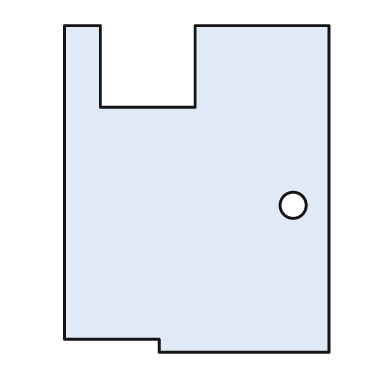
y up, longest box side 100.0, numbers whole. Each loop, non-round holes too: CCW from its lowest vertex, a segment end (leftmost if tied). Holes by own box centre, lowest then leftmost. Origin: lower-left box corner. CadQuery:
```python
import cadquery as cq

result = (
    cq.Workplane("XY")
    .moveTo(29.0, 0.0)
    .lineTo(81.0, 0.0)
    .lineTo(81.0, 100.0)
    .lineTo(40.0, 100.0)
    .lineTo(40.0, 75.0)
    .lineTo(11.0, 75.0)
    .lineTo(11.0, 100.0)
    .lineTo(0.0, 100.0)
    .lineTo(0.0, 4.0)
    .lineTo(29.0, 4.0)
    .close()
    .moveTo(70.0, 45.0)
    .circle(4.0)
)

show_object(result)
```